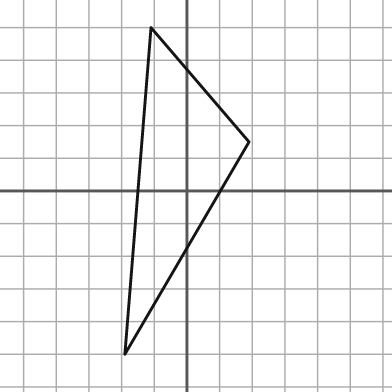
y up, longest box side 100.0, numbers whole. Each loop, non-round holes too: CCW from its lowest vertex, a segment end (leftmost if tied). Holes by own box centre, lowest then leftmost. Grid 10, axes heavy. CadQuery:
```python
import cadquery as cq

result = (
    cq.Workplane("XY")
    .moveTo(-19.0, -50.0)
    .lineTo(19.0, 15.0)
    .lineTo(-11.0, 50.0)
    .close()
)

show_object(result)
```